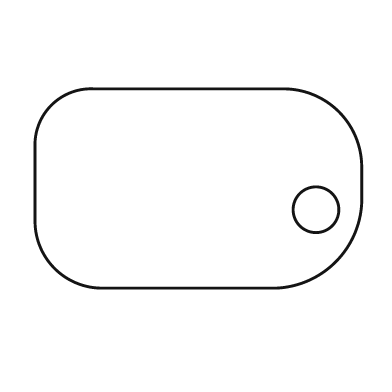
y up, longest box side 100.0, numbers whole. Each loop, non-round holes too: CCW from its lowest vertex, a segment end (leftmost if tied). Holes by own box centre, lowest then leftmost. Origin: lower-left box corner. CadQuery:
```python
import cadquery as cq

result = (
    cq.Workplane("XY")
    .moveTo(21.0, 0.0)
    .lineTo(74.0, 0.0)
    .threePointArc((92.0, 8.0), (100.0, 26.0))
    .lineTo(100.0, 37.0)
    .threePointArc((93.0, 54.0), (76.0, 61.0))
    .lineTo(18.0, 61.0)
    .threePointArc((5.0, 56.0), (0.0, 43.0))
    .lineTo(0.0, 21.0)
    .threePointArc((6.0, 6.0), (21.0, 0.0))
    .close()
    .moveTo(86.0, 24.0)
    .circle(7.0)
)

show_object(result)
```